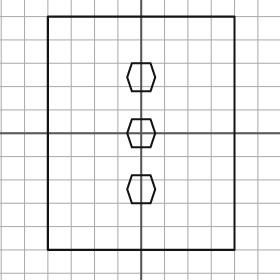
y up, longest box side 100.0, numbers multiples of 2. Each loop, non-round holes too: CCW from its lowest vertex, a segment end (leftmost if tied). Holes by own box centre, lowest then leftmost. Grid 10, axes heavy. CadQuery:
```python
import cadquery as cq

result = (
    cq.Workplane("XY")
    .moveTo(-40.0, -50.0)
    .lineTo(40.0, -50.0)
    .lineTo(40.0, 50.0)
    .lineTo(-40.0, 50.0)
    .close()
    .moveTo(-4.0, -30.0)
    .lineTo(4.0, -30.0)
    .lineTo(6.0, -24.0)
    .lineTo(4.0, -18.0)
    .lineTo(-4.0, -18.0)
    .lineTo(-6.0, -24.0)
    .close()
    .moveTo(-4.0, -6.0)
    .lineTo(4.0, -6.0)
    .lineTo(6.0, 0.0)
    .lineTo(4.0, 6.0)
    .lineTo(-4.0, 6.0)
    .lineTo(-6.0, 0.0)
    .close()
    .moveTo(-4.0, 18.0)
    .lineTo(4.0, 18.0)
    .lineTo(6.0, 24.0)
    .lineTo(4.0, 30.0)
    .lineTo(-4.0, 30.0)
    .lineTo(-6.0, 24.0)
    .close()
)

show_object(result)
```